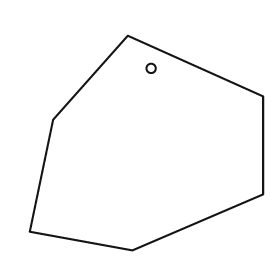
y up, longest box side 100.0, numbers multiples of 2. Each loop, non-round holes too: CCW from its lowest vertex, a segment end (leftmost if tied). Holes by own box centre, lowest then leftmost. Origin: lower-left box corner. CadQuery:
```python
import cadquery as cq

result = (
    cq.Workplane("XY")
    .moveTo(44.0, 0.0)
    .lineTo(100.0, 24.0)
    .lineTo(100.0, 66.0)
    .lineTo(42.0, 92.0)
    .lineTo(10.0, 56.0)
    .lineTo(0.0, 8.0)
    .close()
    .moveTo(52.0, 78.0)
    .circle(2.0)
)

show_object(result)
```